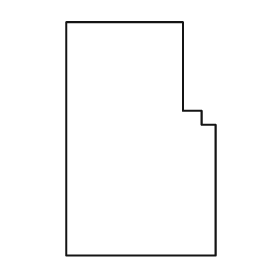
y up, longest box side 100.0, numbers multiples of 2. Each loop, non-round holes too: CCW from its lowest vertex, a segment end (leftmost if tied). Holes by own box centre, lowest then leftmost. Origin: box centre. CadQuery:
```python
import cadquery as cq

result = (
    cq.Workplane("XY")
    .moveTo(-32.0, -50.0)
    .lineTo(32.0, -50.0)
    .lineTo(32.0, 6.0)
    .lineTo(26.0, 6.0)
    .lineTo(26.0, 12.0)
    .lineTo(18.0, 12.0)
    .lineTo(18.0, 50.0)
    .lineTo(-32.0, 50.0)
    .close()
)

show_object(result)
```